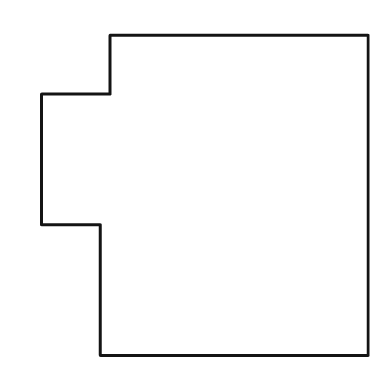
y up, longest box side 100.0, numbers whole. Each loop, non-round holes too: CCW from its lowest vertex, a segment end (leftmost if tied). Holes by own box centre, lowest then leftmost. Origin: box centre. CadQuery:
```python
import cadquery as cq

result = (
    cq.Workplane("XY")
    .moveTo(-32.0, -49.0)
    .lineTo(50.0, -49.0)
    .lineTo(50.0, 49.0)
    .lineTo(-29.0, 49.0)
    .lineTo(-29.0, 31.0)
    .lineTo(-50.0, 31.0)
    .lineTo(-50.0, -9.0)
    .lineTo(-32.0, -9.0)
    .close()
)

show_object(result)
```